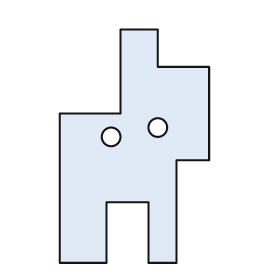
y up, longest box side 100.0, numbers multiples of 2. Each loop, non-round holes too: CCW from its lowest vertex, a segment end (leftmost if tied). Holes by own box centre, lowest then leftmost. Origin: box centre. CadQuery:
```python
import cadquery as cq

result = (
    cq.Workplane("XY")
    .moveTo(-32.0, -50.0)
    .lineTo(-12.0, -50.0)
    .lineTo(-12.0, -24.0)
    .lineTo(6.0, -24.0)
    .lineTo(6.0, -50.0)
    .lineTo(18.0, -50.0)
    .lineTo(18.0, -6.0)
    .lineTo(32.0, -6.0)
    .lineTo(32.0, 34.0)
    .lineTo(10.0, 34.0)
    .lineTo(10.0, 50.0)
    .lineTo(-6.0, 50.0)
    .lineTo(-6.0, 14.0)
    .lineTo(-32.0, 14.0)
    .close()
    .moveTo(-10.0, 4.0)
    .circle(4.0)
    .moveTo(10.0, 8.0)
    .circle(4.0)
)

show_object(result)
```